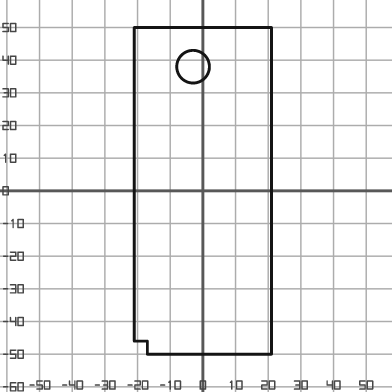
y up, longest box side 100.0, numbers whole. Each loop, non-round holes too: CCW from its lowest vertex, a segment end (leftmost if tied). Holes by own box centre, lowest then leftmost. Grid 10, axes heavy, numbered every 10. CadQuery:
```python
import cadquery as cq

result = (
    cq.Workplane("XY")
    .moveTo(-17.0, -50.0)
    .lineTo(21.0, -50.0)
    .lineTo(21.0, 50.0)
    .lineTo(-21.0, 50.0)
    .lineTo(-21.0, -46.0)
    .lineTo(-17.0, -46.0)
    .close()
    .moveTo(-3.0, 38.0)
    .circle(5.0)
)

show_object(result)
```